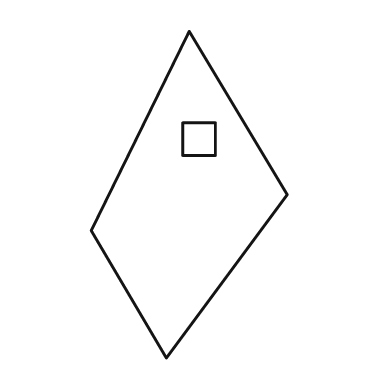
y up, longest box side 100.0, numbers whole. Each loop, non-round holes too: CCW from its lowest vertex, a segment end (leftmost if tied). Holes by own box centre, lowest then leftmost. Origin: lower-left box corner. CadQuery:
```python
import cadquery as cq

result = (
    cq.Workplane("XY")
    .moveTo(23.0, 0.0)
    .lineTo(60.0, 50.0)
    .lineTo(30.0, 100.0)
    .lineTo(0.0, 39.0)
    .close()
    .moveTo(28.0, 62.0)
    .lineTo(38.0, 62.0)
    .lineTo(38.0, 72.0)
    .lineTo(28.0, 72.0)
    .close()
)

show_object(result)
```